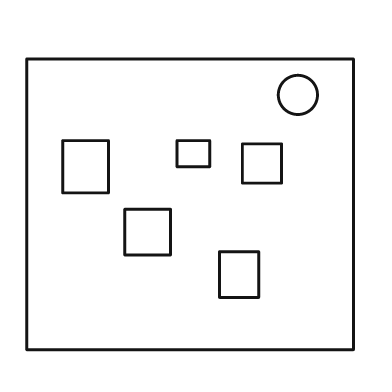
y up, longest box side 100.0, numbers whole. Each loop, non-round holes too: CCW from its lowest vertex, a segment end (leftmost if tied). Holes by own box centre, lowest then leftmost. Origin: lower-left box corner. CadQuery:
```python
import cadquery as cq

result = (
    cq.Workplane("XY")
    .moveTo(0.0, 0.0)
    .lineTo(100.0, 0.0)
    .lineTo(100.0, 89.0)
    .lineTo(0.0, 89.0)
    .close()
    .moveTo(59.0, 16.0)
    .lineTo(71.0, 16.0)
    .lineTo(71.0, 30.0)
    .lineTo(59.0, 30.0)
    .close()
    .moveTo(30.0, 29.0)
    .lineTo(44.0, 29.0)
    .lineTo(44.0, 43.0)
    .lineTo(30.0, 43.0)
    .close()
    .moveTo(11.0, 48.0)
    .lineTo(25.0, 48.0)
    .lineTo(25.0, 64.0)
    .lineTo(11.0, 64.0)
    .close()
    .moveTo(66.0, 51.0)
    .lineTo(78.0, 51.0)
    .lineTo(78.0, 63.0)
    .lineTo(66.0, 63.0)
    .close()
    .moveTo(46.0, 56.0)
    .lineTo(56.0, 56.0)
    .lineTo(56.0, 64.0)
    .lineTo(46.0, 64.0)
    .close()
    .moveTo(83.0, 78.0)
    .circle(6.0)
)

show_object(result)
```